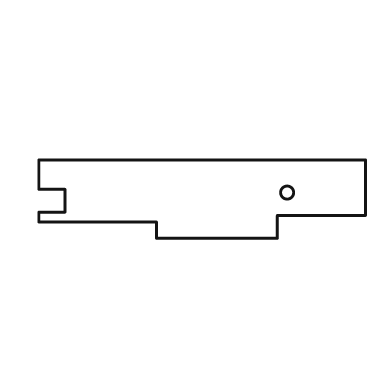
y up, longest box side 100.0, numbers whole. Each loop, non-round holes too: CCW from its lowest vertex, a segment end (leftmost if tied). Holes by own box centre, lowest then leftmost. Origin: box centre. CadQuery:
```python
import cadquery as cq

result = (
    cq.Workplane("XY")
    .moveTo(-14.0, -12.0)
    .lineTo(23.0, -12.0)
    .lineTo(23.0, -5.0)
    .lineTo(50.0, -5.0)
    .lineTo(50.0, 12.0)
    .lineTo(-50.0, 12.0)
    .lineTo(-50.0, 3.0)
    .lineTo(-42.0, 3.0)
    .lineTo(-42.0, -4.0)
    .lineTo(-50.0, -4.0)
    .lineTo(-50.0, -7.0)
    .lineTo(-14.0, -7.0)
    .close()
    .moveTo(26.0, 2.0)
    .circle(2.0)
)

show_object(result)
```